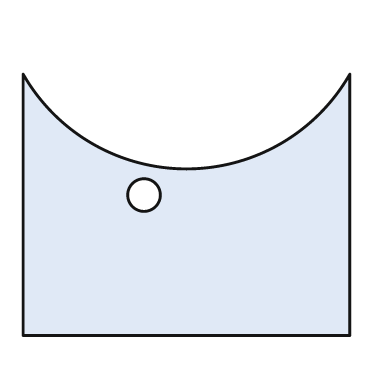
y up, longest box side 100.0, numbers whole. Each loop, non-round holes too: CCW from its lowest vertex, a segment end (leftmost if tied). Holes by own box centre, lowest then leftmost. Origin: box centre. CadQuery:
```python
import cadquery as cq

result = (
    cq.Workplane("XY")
    .moveTo(-50.0, -40.0)
    .lineTo(50.0, -40.0)
    .lineTo(50.0, 40.0)
    .threePointArc((0.0, 11.0), (-50.0, 40.0))
    .close()
    .moveTo(-13.0, 3.0)
    .circle(5.0)
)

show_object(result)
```